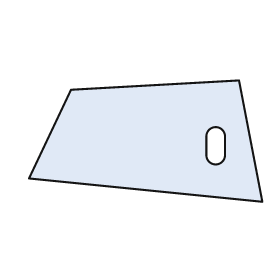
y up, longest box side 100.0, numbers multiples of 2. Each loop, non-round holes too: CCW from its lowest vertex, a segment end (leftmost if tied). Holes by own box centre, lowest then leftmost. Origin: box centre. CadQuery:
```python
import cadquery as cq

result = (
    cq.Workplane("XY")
    .moveTo(50.0, -26.0)
    .lineTo(40.0, 26.0)
    .lineTo(-32.0, 22.0)
    .lineTo(-50.0, -16.0)
    .close()
    .moveTo(26.0, -6.0)
    .threePointArc((30.0, -10.0), (34.0, -6.0))
    .lineTo(34.0, 2.0)
    .threePointArc((30.0, 6.0), (26.0, 2.0))
    .close()
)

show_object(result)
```